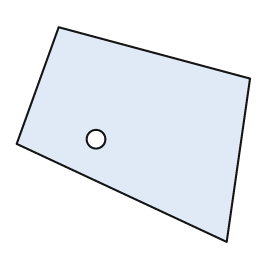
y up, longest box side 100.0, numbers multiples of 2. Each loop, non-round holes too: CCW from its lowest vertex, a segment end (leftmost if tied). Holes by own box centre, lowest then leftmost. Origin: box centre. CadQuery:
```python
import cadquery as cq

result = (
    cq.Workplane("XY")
    .moveTo(40.0, -46.0)
    .lineTo(50.0, 24.0)
    .lineTo(-32.0, 46.0)
    .lineTo(-50.0, -4.0)
    .close()
    .moveTo(-16.0, -2.0)
    .circle(4.0)
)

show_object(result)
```